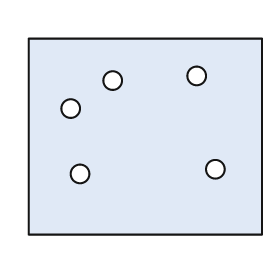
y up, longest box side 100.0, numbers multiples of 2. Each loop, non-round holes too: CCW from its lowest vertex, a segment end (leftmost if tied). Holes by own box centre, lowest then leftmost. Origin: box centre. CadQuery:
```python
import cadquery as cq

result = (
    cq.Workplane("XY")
    .moveTo(-50.0, -42.0)
    .lineTo(50.0, -42.0)
    .lineTo(50.0, 42.0)
    .lineTo(-50.0, 42.0)
    .close()
    .moveTo(-28.0, -16.0)
    .circle(4.0)
    .moveTo(30.0, -14.0)
    .circle(4.0)
    .moveTo(-32.0, 12.0)
    .circle(4.0)
    .moveTo(-14.0, 24.0)
    .circle(4.0)
    .moveTo(22.0, 26.0)
    .circle(4.0)
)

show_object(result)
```